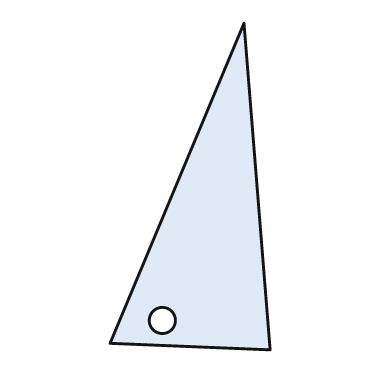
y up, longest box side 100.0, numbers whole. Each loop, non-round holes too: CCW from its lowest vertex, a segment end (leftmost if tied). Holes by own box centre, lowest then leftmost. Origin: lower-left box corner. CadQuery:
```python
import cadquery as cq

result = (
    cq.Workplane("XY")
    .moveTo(49.0, 0.0)
    .lineTo(41.0, 100.0)
    .lineTo(0.0, 2.0)
    .close()
    .moveTo(16.0, 9.0)
    .circle(4.0)
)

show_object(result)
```